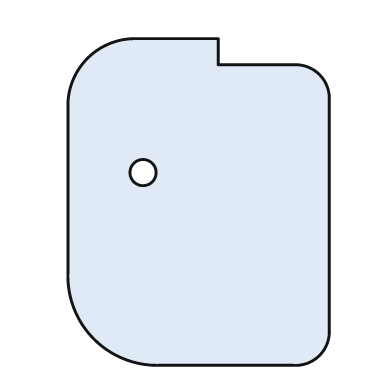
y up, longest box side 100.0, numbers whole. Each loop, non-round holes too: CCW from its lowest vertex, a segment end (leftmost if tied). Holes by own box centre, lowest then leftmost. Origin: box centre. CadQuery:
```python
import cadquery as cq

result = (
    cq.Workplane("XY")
    .moveTo(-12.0, -50.0)
    .lineTo(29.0, -50.0)
    .threePointArc((37.0, -47.0), (40.0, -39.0))
    .lineTo(40.0, 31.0)
    .threePointArc((37.0, 39.0), (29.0, 42.0))
    .lineTo(6.0, 42.0)
    .lineTo(6.0, 50.0)
    .lineTo(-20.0, 50.0)
    .threePointArc((-34.0, 44.0), (-40.0, 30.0))
    .lineTo(-40.0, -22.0)
    .threePointArc((-32.0, -42.0), (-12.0, -50.0))
    .close()
    .moveTo(-17.0, 9.0)
    .circle(4.0)
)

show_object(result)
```